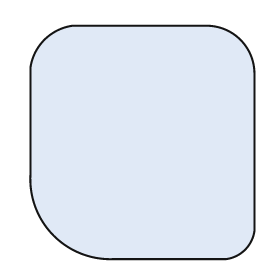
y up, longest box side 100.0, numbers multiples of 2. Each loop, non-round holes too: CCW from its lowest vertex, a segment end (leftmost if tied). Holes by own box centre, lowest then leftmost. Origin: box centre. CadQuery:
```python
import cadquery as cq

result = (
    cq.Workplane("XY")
    .moveTo(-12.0, -50.0)
    .lineTo(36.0, -50.0)
    .threePointArc((44.0, -46.0), (48.0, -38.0))
    .lineTo(48.0, 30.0)
    .threePointArc((42.0, 44.0), (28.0, 50.0))
    .lineTo(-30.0, 50.0)
    .threePointArc((-42.0, 44.0), (-48.0, 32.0))
    .lineTo(-48.0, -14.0)
    .threePointArc((-38.0, -40.0), (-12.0, -50.0))
    .close()
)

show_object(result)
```